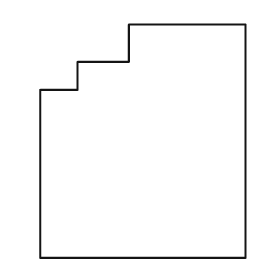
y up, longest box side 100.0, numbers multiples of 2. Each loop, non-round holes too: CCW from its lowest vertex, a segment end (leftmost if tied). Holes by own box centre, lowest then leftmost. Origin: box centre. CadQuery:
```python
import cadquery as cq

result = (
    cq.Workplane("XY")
    .moveTo(-44.0, -50.0)
    .lineTo(44.0, -50.0)
    .lineTo(44.0, 50.0)
    .lineTo(-6.0, 50.0)
    .lineTo(-6.0, 34.0)
    .lineTo(-28.0, 34.0)
    .lineTo(-28.0, 22.0)
    .lineTo(-44.0, 22.0)
    .close()
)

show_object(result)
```